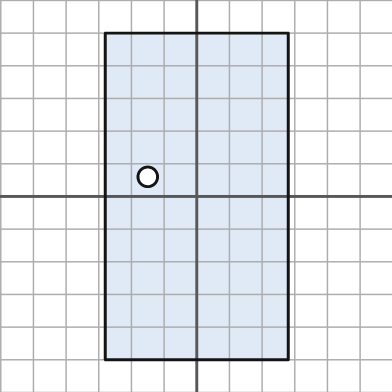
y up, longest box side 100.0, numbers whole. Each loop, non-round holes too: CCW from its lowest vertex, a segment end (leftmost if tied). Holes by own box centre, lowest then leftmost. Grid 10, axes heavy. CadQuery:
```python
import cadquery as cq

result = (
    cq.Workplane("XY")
    .moveTo(-28.0, -50.0)
    .lineTo(28.0, -50.0)
    .lineTo(28.0, 50.0)
    .lineTo(-28.0, 50.0)
    .close()
    .moveTo(-15.0, 6.0)
    .circle(3.0)
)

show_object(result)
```